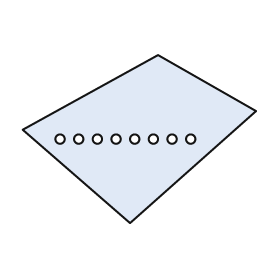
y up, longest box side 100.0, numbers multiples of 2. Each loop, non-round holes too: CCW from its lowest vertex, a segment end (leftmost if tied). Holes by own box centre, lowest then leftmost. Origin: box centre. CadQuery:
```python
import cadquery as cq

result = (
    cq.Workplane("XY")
    .moveTo(-4.0, -36.0)
    .lineTo(50.0, 12.0)
    .lineTo(8.0, 36.0)
    .lineTo(-50.0, 4.0)
    .close()
    .moveTo(-34.0, 0.0)
    .circle(2.0)
    .moveTo(-26.0, 0.0)
    .circle(2.0)
    .moveTo(-18.0, 0.0)
    .circle(2.0)
    .moveTo(-10.0, 0.0)
    .circle(2.0)
    .moveTo(-2.0, 0.0)
    .circle(2.0)
    .moveTo(6.0, 0.0)
    .circle(2.0)
    .moveTo(14.0, 0.0)
    .circle(2.0)
    .moveTo(22.0, 0.0)
    .circle(2.0)
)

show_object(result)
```